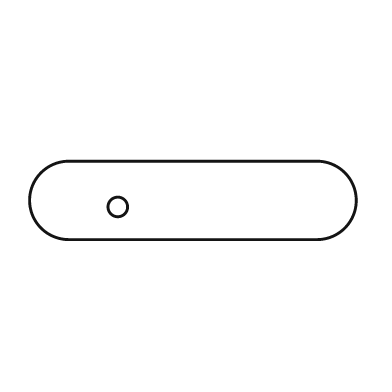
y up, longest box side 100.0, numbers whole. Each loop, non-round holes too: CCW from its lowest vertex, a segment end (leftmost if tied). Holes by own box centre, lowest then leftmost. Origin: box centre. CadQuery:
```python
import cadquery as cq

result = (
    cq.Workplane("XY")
    .moveTo(-38.0, -12.0)
    .lineTo(38.0, -12.0)
    .threePointArc((50.0, 0.0), (38.0, 12.0))
    .lineTo(-38.0, 12.0)
    .threePointArc((-50.0, 0.0), (-38.0, -12.0))
    .close()
    .moveTo(-23.0, -2.0)
    .circle(3.0)
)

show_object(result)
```